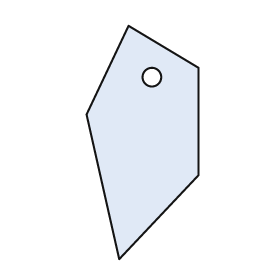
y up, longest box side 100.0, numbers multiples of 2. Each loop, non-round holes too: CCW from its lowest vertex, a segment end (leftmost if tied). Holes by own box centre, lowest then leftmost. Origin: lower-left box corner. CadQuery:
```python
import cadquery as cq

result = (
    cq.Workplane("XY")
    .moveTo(14.0, 0.0)
    .lineTo(48.0, 36.0)
    .lineTo(48.0, 82.0)
    .lineTo(18.0, 100.0)
    .lineTo(0.0, 62.0)
    .close()
    .moveTo(28.0, 78.0)
    .circle(4.0)
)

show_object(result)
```